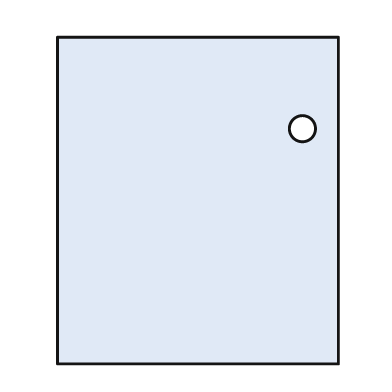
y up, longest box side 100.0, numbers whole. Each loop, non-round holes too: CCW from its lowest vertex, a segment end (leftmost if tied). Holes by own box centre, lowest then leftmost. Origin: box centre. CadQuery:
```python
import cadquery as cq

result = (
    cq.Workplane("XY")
    .moveTo(-43.0, -50.0)
    .lineTo(43.0, -50.0)
    .lineTo(43.0, 50.0)
    .lineTo(-43.0, 50.0)
    .close()
    .moveTo(32.0, 22.0)
    .circle(4.0)
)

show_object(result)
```